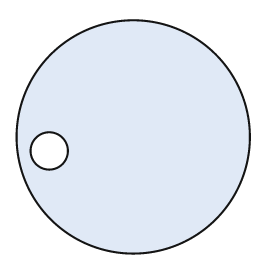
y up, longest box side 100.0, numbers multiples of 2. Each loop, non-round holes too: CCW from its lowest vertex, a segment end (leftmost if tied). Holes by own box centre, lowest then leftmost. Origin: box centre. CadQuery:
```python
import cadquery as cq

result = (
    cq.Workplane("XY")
    .moveTo(0.0, 0.0)
    .circle(50.0)
    .moveTo(-36.0, -6.0)
    .circle(8.0)
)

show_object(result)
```